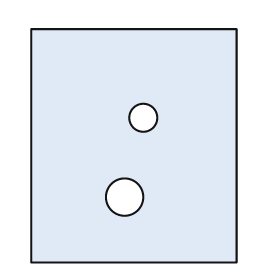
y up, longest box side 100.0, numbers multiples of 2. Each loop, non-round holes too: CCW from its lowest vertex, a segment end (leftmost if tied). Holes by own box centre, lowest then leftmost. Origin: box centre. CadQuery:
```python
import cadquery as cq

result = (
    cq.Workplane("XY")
    .moveTo(-44.0, -50.0)
    .lineTo(44.0, -50.0)
    .lineTo(44.0, 50.0)
    .lineTo(-44.0, 50.0)
    .close()
    .moveTo(-4.0, -22.0)
    .circle(8.0)
    .moveTo(4.0, 12.0)
    .circle(6.0)
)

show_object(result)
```